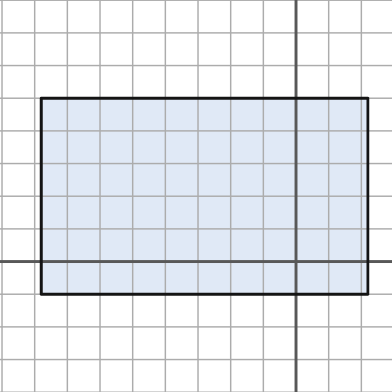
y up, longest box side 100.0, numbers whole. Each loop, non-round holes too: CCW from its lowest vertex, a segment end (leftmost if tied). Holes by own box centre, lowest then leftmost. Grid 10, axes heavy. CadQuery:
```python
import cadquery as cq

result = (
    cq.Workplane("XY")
    .moveTo(-78.0, -10.0)
    .lineTo(22.0, -10.0)
    .lineTo(22.0, 50.0)
    .lineTo(-78.0, 50.0)
    .close()
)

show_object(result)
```